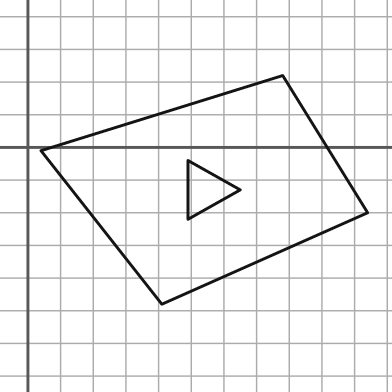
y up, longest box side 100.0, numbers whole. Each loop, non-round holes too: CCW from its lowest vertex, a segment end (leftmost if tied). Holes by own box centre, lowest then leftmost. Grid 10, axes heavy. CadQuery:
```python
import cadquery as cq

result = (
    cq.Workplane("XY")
    .moveTo(41.0, -48.0)
    .lineTo(104.0, -20.0)
    .lineTo(78.0, 22.0)
    .lineTo(4.0, -1.0)
    .close()
    .moveTo(49.0, -22.0)
    .lineTo(65.0, -13.0)
    .lineTo(49.0, -4.0)
    .close()
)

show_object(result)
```